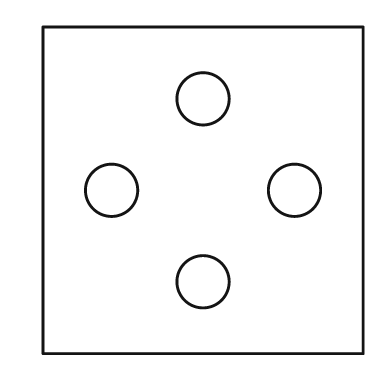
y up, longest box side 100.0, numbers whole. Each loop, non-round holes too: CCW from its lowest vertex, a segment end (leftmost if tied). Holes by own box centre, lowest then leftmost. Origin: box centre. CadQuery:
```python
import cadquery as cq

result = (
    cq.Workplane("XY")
    .moveTo(-49.0, -50.0)
    .lineTo(49.0, -50.0)
    .lineTo(49.0, 50.0)
    .lineTo(-49.0, 50.0)
    .close()
    .moveTo(0.0, -28.0)
    .circle(8.0)
    .moveTo(-28.0, 0.0)
    .circle(8.0)
    .moveTo(28.0, 0.0)
    .circle(8.0)
    .moveTo(0.0, 28.0)
    .circle(8.0)
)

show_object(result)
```